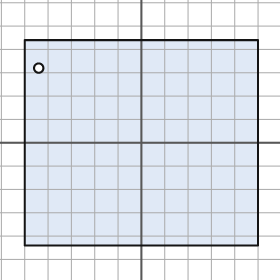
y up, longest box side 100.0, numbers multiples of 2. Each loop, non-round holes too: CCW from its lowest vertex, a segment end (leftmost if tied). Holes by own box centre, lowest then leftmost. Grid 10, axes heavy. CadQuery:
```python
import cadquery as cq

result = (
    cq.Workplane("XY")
    .moveTo(-50.0, -44.0)
    .lineTo(50.0, -44.0)
    .lineTo(50.0, 44.0)
    .lineTo(-50.0, 44.0)
    .close()
    .moveTo(-44.0, 32.0)
    .circle(2.0)
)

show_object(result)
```